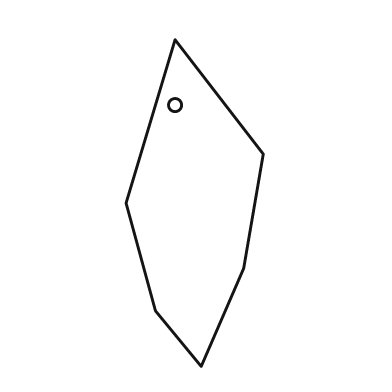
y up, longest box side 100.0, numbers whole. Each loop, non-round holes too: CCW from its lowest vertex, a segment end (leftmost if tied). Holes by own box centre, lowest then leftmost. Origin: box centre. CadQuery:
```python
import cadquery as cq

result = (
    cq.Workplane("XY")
    .moveTo(2.0, -50.0)
    .lineTo(15.0, -20.0)
    .lineTo(21.0, 15.0)
    .lineTo(-6.0, 50.0)
    .lineTo(-21.0, 0.0)
    .lineTo(-12.0, -33.0)
    .close()
    .moveTo(-6.0, 30.0)
    .circle(2.0)
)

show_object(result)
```